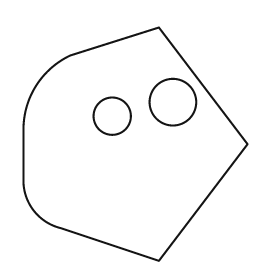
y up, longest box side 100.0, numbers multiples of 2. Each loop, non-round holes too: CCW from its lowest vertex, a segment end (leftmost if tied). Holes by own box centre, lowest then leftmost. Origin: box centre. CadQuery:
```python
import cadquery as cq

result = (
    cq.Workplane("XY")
    .moveTo(10.0, -50.0)
    .lineTo(48.0, 0.0)
    .lineTo(10.0, 50.0)
    .lineTo(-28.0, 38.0)
    .threePointArc((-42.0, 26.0), (-48.0, 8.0))
    .lineTo(-48.0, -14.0)
    .threePointArc((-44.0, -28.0), (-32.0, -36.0))
    .close()
    .moveTo(-10.0, 12.0)
    .circle(8.0)
    .moveTo(16.0, 18.0)
    .circle(10.0)
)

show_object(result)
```